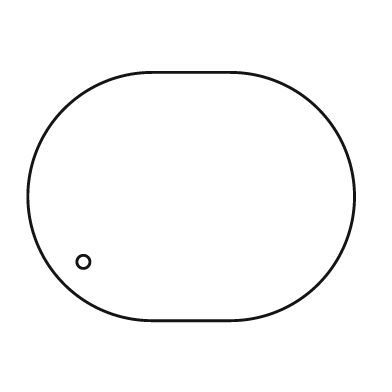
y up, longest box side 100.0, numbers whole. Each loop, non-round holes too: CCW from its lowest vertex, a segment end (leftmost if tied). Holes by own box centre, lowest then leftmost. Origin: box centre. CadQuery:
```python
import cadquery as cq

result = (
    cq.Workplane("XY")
    .moveTo(-12.0, -38.0)
    .lineTo(12.0, -38.0)
    .threePointArc((50.0, 0.0), (12.0, 38.0))
    .lineTo(-12.0, 38.0)
    .threePointArc((-50.0, 0.0), (-12.0, -38.0))
    .close()
    .moveTo(-33.0, -20.0)
    .circle(2.0)
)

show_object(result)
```